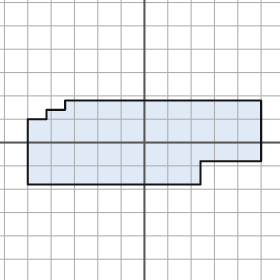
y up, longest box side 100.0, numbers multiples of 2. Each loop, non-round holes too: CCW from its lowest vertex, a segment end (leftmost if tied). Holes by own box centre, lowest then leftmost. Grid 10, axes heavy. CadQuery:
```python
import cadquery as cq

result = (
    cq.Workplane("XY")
    .moveTo(-50.0, -18.0)
    .lineTo(24.0, -18.0)
    .lineTo(24.0, -8.0)
    .lineTo(50.0, -8.0)
    .lineTo(50.0, 18.0)
    .lineTo(-34.0, 18.0)
    .lineTo(-34.0, 14.0)
    .lineTo(-42.0, 14.0)
    .lineTo(-42.0, 10.0)
    .lineTo(-50.0, 10.0)
    .close()
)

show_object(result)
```